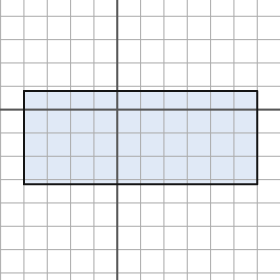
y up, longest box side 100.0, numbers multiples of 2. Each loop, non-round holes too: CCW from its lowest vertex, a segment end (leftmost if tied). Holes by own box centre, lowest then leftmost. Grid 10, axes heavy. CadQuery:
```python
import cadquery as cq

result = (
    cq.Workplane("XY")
    .moveTo(-40.0, -32.0)
    .lineTo(60.0, -32.0)
    .lineTo(60.0, 8.0)
    .lineTo(-40.0, 8.0)
    .close()
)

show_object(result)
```